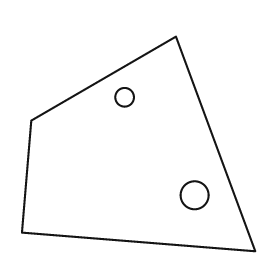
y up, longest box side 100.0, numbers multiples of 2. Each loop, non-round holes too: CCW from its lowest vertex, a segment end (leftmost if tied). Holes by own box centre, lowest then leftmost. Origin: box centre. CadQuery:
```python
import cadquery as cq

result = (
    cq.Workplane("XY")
    .moveTo(50.0, -46.0)
    .lineTo(16.0, 46.0)
    .lineTo(-46.0, 10.0)
    .lineTo(-50.0, -38.0)
    .close()
    .moveTo(24.0, -22.0)
    .circle(6.0)
    .moveTo(-6.0, 20.0)
    .circle(4.0)
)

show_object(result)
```